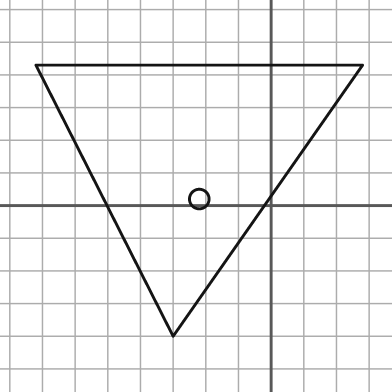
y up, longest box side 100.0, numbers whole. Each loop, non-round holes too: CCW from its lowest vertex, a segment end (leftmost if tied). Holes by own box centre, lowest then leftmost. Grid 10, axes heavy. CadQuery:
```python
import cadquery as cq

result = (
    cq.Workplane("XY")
    .moveTo(-30.0, -40.0)
    .lineTo(28.0, 43.0)
    .lineTo(-72.0, 43.0)
    .close()
    .moveTo(-22.0, 2.0)
    .circle(3.0)
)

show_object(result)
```